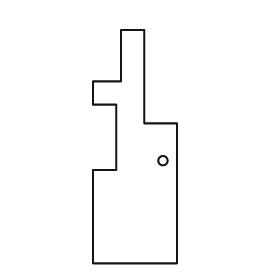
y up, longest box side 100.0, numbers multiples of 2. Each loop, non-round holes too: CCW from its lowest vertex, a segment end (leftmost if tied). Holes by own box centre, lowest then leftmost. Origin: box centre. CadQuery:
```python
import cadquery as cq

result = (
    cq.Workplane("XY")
    .moveTo(-18.0, -50.0)
    .lineTo(18.0, -50.0)
    .lineTo(18.0, 10.0)
    .lineTo(4.0, 10.0)
    .lineTo(4.0, 50.0)
    .lineTo(-6.0, 50.0)
    .lineTo(-6.0, 28.0)
    .lineTo(-18.0, 28.0)
    .lineTo(-18.0, 18.0)
    .lineTo(-8.0, 18.0)
    .lineTo(-8.0, -10.0)
    .lineTo(-18.0, -10.0)
    .close()
    .moveTo(12.0, -6.0)
    .circle(2.0)
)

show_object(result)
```